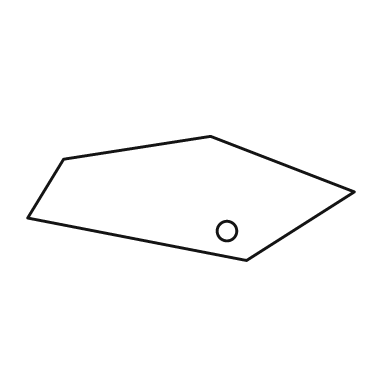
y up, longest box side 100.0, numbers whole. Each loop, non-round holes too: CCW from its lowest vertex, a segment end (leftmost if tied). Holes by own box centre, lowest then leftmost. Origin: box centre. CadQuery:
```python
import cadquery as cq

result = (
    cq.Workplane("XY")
    .moveTo(17.0, -19.0)
    .lineTo(50.0, 2.0)
    .lineTo(6.0, 19.0)
    .lineTo(-39.0, 12.0)
    .lineTo(-50.0, -6.0)
    .close()
    .moveTo(11.0, -10.0)
    .circle(3.0)
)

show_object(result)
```